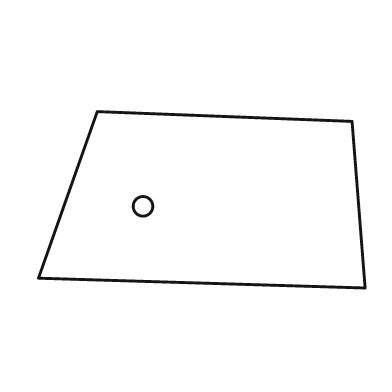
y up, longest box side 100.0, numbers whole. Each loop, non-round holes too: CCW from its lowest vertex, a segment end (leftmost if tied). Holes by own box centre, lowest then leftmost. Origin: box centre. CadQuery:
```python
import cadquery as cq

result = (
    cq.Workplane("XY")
    .moveTo(50.0, -27.0)
    .lineTo(46.0, 24.0)
    .lineTo(-32.0, 27.0)
    .lineTo(-50.0, -24.0)
    .close()
    .moveTo(-18.0, -2.0)
    .circle(3.0)
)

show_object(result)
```